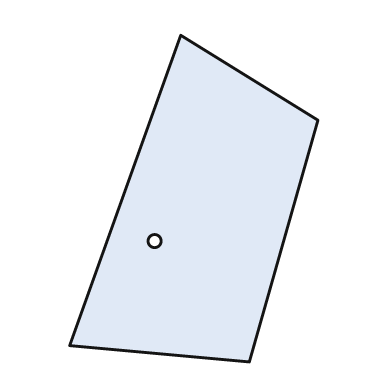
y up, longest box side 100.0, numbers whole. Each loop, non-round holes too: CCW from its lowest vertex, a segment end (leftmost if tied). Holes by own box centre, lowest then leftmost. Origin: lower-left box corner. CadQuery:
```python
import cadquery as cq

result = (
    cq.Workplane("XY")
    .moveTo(55.0, 0.0)
    .lineTo(76.0, 74.0)
    .lineTo(34.0, 100.0)
    .lineTo(0.0, 5.0)
    .close()
    .moveTo(26.0, 37.0)
    .circle(2.0)
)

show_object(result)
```